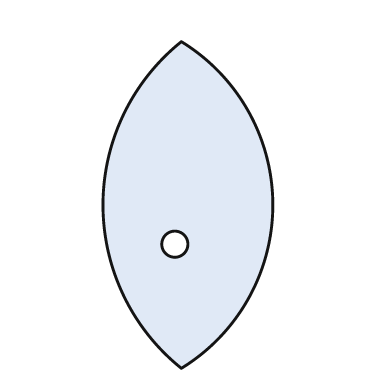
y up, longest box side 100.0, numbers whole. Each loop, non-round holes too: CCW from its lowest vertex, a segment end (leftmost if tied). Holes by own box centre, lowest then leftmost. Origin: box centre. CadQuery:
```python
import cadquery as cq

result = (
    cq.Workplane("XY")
    .moveTo(-2.0, -50.0)
    .threePointArc((26.0, 0.0), (-2.0, 50.0))
    .threePointArc((-26.0, 0.0), (-2.0, -50.0))
    .close()
    .moveTo(-4.0, -12.0)
    .circle(4.0)
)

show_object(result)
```